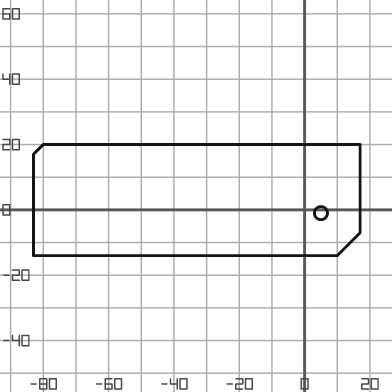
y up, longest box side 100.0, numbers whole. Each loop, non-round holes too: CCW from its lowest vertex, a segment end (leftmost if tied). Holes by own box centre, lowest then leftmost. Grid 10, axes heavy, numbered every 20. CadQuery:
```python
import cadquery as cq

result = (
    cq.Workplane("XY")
    .moveTo(-83.0, -14.0)
    .lineTo(10.0, -14.0)
    .lineTo(17.0, -7.0)
    .lineTo(17.0, 20.0)
    .lineTo(-80.0, 20.0)
    .lineTo(-83.0, 17.0)
    .close()
    .moveTo(5.0, -1.0)
    .circle(2.0)
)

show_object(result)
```